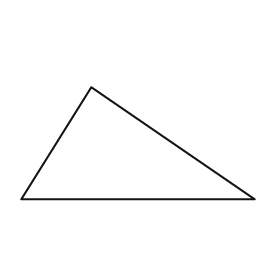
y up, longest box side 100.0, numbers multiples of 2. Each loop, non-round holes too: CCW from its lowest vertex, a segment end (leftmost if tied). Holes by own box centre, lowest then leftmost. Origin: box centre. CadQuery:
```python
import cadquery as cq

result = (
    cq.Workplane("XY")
    .moveTo(-50.0, -24.0)
    .lineTo(50.0, -24.0)
    .lineTo(-20.0, 24.0)
    .close()
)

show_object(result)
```